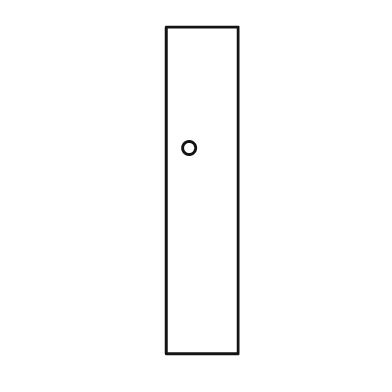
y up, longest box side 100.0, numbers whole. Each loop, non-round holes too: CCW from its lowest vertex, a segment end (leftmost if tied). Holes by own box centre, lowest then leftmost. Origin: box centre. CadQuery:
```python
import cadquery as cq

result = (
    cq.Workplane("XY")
    .moveTo(-11.0, -50.0)
    .lineTo(11.0, -50.0)
    .lineTo(11.0, 50.0)
    .lineTo(-11.0, 50.0)
    .close()
    .moveTo(-4.0, 13.0)
    .circle(2.0)
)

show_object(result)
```